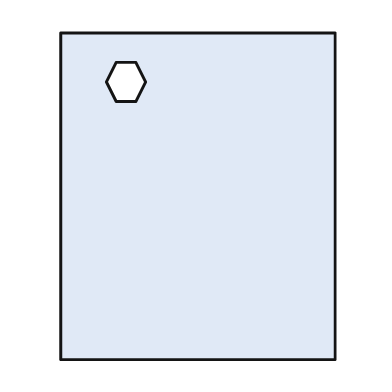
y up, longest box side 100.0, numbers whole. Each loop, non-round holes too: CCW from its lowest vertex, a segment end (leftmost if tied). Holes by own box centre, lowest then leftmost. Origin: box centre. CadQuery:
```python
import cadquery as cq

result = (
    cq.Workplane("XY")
    .moveTo(-42.0, -50.0)
    .lineTo(42.0, -50.0)
    .lineTo(42.0, 50.0)
    .lineTo(-42.0, 50.0)
    .close()
    .moveTo(-25.0, 29.0)
    .lineTo(-19.0, 29.0)
    .lineTo(-16.0, 35.0)
    .lineTo(-19.0, 41.0)
    .lineTo(-25.0, 41.0)
    .lineTo(-28.0, 35.0)
    .close()
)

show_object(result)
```